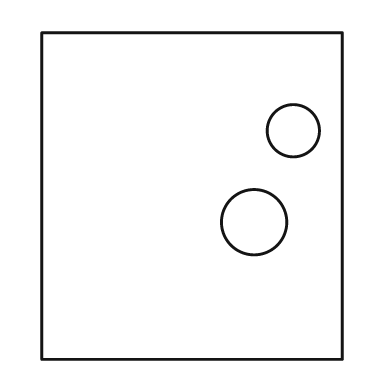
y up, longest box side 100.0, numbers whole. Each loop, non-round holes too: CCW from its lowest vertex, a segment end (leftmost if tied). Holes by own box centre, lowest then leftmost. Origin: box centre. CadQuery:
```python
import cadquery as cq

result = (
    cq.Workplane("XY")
    .moveTo(-46.0, -50.0)
    .lineTo(46.0, -50.0)
    .lineTo(46.0, 50.0)
    .lineTo(-46.0, 50.0)
    .close()
    .moveTo(19.0, -8.0)
    .circle(10.0)
    .moveTo(31.0, 20.0)
    .circle(8.0)
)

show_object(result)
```